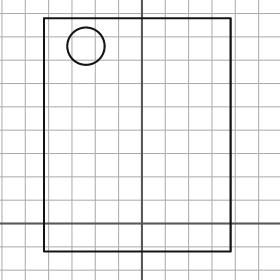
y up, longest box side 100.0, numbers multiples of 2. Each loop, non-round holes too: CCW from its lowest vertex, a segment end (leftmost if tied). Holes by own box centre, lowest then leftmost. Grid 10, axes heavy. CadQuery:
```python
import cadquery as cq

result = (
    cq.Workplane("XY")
    .moveTo(-42.0, -12.0)
    .lineTo(38.0, -12.0)
    .lineTo(38.0, 88.0)
    .lineTo(-42.0, 88.0)
    .close()
    .moveTo(-24.0, 76.0)
    .circle(8.0)
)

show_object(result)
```